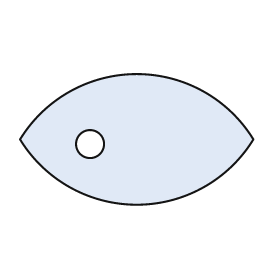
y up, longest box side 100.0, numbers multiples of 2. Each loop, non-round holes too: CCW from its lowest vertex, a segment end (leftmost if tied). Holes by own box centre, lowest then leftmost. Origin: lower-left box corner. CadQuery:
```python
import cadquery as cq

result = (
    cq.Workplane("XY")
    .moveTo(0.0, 28.0)
    .threePointArc((50.0, 0.0), (100.0, 28.0))
    .threePointArc((50.0, 56.0), (0.0, 28.0))
    .close()
    .moveTo(30.0, 26.0)
    .circle(6.0)
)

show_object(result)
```